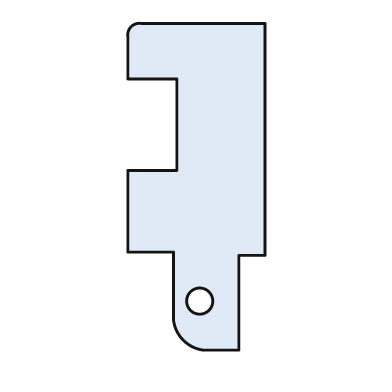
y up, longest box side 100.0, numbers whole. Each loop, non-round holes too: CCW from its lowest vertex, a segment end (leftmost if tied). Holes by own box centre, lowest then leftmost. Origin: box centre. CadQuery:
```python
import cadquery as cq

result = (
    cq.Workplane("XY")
    .moveTo(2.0, -50.0)
    .lineTo(13.0, -50.0)
    .lineTo(13.0, -21.0)
    .lineTo(21.0, -21.0)
    .lineTo(21.0, 50.0)
    .lineTo(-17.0, 50.0)
    .threePointArc((-20.0, 49.0), (-21.0, 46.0))
    .lineTo(-21.0, 33.0)
    .lineTo(-6.0, 33.0)
    .lineTo(-6.0, 5.0)
    .lineTo(-21.0, 5.0)
    .lineTo(-21.0, -20.0)
    .lineTo(-7.0, -20.0)
    .lineTo(-7.0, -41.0)
    .threePointArc((-4.0, -47.0), (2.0, -50.0))
    .close()
    .moveTo(1.0, -35.0)
    .circle(4.0)
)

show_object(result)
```